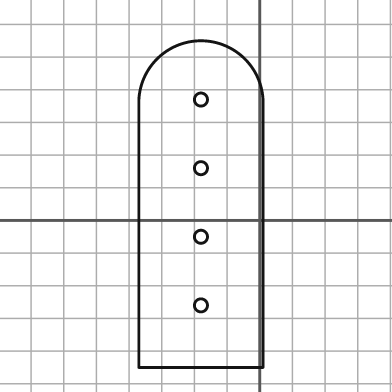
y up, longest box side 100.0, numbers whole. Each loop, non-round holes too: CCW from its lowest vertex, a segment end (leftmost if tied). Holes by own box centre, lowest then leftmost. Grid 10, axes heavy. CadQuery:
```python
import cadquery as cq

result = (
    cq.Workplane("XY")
    .moveTo(-37.0, -45.0)
    .lineTo(1.0, -45.0)
    .lineTo(1.0, 37.0)
    .threePointArc((-18.0, 55.0), (-37.0, 37.0))
    .close()
    .moveTo(-18.0, -26.0)
    .circle(2.0)
    .moveTo(-18.0, -5.0)
    .circle(2.0)
    .moveTo(-18.0, 16.0)
    .circle(2.0)
    .moveTo(-18.0, 37.0)
    .circle(2.0)
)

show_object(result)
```